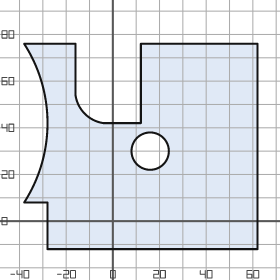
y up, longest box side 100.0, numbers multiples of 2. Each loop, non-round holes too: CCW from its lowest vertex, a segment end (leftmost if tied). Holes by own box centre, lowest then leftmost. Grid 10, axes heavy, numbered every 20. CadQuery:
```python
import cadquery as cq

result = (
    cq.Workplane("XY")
    .moveTo(-28.0, -12.0)
    .lineTo(62.0, -12.0)
    .lineTo(62.0, 76.0)
    .lineTo(12.0, 76.0)
    .lineTo(12.0, 42.0)
    .lineTo(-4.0, 42.0)
    .threePointArc((-12.0, 46.0), (-16.0, 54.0))
    .lineTo(-16.0, 76.0)
    .lineTo(-38.0, 76.0)
    .threePointArc((-28.0, 42.0), (-38.0, 8.0))
    .lineTo(-28.0, 8.0)
    .close()
    .moveTo(16.0, 30.0)
    .circle(8.0)
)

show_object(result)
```